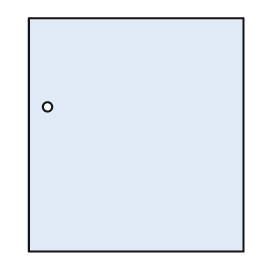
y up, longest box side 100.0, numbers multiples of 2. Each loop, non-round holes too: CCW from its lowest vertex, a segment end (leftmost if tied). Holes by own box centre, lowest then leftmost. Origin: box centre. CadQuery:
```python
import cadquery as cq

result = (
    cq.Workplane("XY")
    .moveTo(-46.0, -50.0)
    .lineTo(46.0, -50.0)
    .lineTo(46.0, 50.0)
    .lineTo(-46.0, 50.0)
    .close()
    .moveTo(-38.0, 12.0)
    .circle(2.0)
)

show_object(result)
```